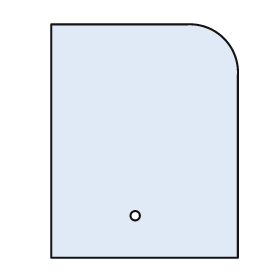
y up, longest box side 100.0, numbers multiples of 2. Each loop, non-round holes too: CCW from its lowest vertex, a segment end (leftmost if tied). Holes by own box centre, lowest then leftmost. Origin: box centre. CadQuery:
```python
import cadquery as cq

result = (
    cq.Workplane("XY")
    .moveTo(-40.0, -50.0)
    .lineTo(40.0, -50.0)
    .lineTo(40.0, 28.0)
    .threePointArc((34.0, 44.0), (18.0, 50.0))
    .lineTo(-40.0, 50.0)
    .close()
    .moveTo(-4.0, -32.0)
    .circle(2.0)
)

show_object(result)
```